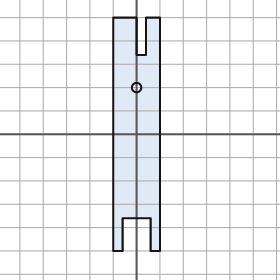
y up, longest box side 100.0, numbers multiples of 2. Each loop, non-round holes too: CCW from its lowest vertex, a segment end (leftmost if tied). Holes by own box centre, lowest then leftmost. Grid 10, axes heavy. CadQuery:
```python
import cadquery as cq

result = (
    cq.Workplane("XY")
    .moveTo(-10.0, -50.0)
    .lineTo(-6.0, -50.0)
    .lineTo(-6.0, -36.0)
    .lineTo(6.0, -36.0)
    .lineTo(6.0, -50.0)
    .lineTo(10.0, -50.0)
    .lineTo(10.0, 50.0)
    .lineTo(4.0, 50.0)
    .lineTo(4.0, 34.0)
    .lineTo(0.0, 34.0)
    .lineTo(0.0, 50.0)
    .lineTo(-10.0, 50.0)
    .close()
    .moveTo(0.0, 20.0)
    .circle(2.0)
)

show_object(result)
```